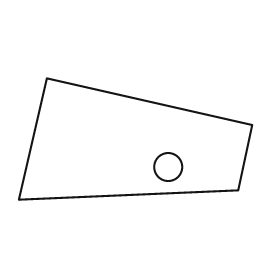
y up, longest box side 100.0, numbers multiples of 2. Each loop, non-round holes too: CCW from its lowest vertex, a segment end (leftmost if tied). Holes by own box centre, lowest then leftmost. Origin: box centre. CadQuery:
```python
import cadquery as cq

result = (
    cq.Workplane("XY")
    .moveTo(-50.0, -26.0)
    .lineTo(44.0, -22.0)
    .lineTo(50.0, 6.0)
    .lineTo(-38.0, 26.0)
    .close()
    .moveTo(14.0, -12.0)
    .circle(6.0)
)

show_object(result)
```